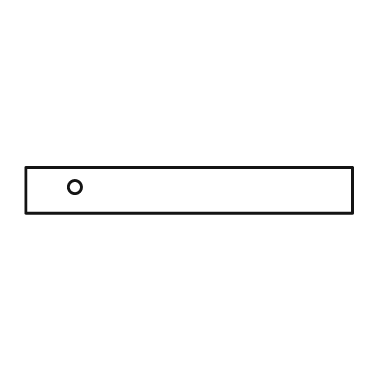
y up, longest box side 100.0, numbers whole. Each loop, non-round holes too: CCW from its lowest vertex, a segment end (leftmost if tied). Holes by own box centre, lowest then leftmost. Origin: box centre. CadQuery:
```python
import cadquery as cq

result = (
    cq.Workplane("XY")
    .moveTo(-50.0, -7.0)
    .lineTo(50.0, -7.0)
    .lineTo(50.0, 7.0)
    .lineTo(-50.0, 7.0)
    .close()
    .moveTo(-35.0, 1.0)
    .circle(2.0)
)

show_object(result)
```